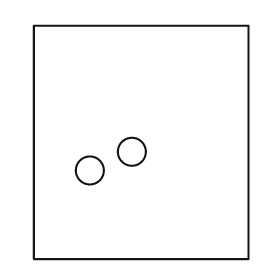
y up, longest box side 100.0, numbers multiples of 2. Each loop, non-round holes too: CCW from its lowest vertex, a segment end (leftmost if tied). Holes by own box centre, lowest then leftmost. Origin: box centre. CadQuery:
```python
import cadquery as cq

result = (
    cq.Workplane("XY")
    .moveTo(-46.0, -50.0)
    .lineTo(46.0, -50.0)
    .lineTo(46.0, 50.0)
    .lineTo(-46.0, 50.0)
    .close()
    .moveTo(-22.0, -12.0)
    .circle(6.0)
    .moveTo(-4.0, -4.0)
    .circle(6.0)
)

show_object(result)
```